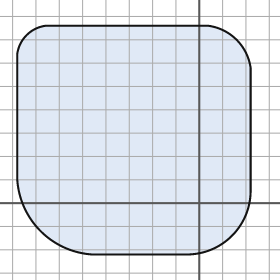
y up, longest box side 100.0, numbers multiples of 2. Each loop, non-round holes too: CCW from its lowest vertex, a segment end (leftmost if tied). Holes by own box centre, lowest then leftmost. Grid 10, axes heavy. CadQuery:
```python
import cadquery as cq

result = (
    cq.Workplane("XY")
    .moveTo(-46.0, -22.0)
    .lineTo(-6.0, -22.0)
    .threePointArc((14.0, -14.0), (22.0, 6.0))
    .lineTo(22.0, 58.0)
    .threePointArc((16.0, 70.0), (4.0, 76.0))
    .lineTo(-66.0, 76.0)
    .threePointArc((-74.0, 72.0), (-78.0, 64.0))
    .lineTo(-78.0, 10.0)
    .threePointArc((-68.0, -12.0), (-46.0, -22.0))
    .close()
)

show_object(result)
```